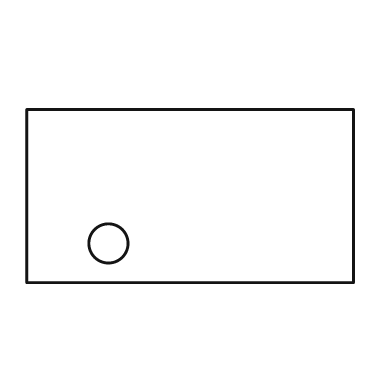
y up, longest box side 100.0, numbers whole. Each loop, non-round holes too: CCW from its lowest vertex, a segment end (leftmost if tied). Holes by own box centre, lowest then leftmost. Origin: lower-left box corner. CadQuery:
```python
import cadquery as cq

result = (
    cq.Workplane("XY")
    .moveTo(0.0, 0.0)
    .lineTo(100.0, 0.0)
    .lineTo(100.0, 53.0)
    .lineTo(0.0, 53.0)
    .close()
    .moveTo(25.0, 12.0)
    .circle(6.0)
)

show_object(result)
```